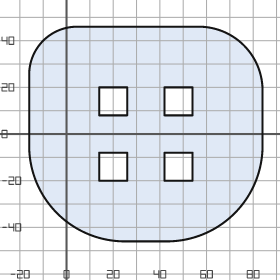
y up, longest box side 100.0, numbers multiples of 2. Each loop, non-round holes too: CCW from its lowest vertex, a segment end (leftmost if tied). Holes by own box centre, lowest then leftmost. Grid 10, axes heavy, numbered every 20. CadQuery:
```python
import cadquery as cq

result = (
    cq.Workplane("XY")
    .moveTo(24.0, -46.0)
    .lineTo(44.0, -46.0)
    .threePointArc((72.0, -34.0), (84.0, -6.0))
    .lineTo(84.0, 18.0)
    .threePointArc((76.0, 38.0), (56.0, 46.0))
    .lineTo(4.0, 46.0)
    .threePointArc((-10.0, 40.0), (-16.0, 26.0))
    .lineTo(-16.0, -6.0)
    .threePointArc((-4.0, -34.0), (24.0, -46.0))
    .close()
    .moveTo(14.0, -20.0)
    .lineTo(26.0, -20.0)
    .lineTo(26.0, -8.0)
    .lineTo(14.0, -8.0)
    .close()
    .moveTo(42.0, -20.0)
    .lineTo(54.0, -20.0)
    .lineTo(54.0, -8.0)
    .lineTo(42.0, -8.0)
    .close()
    .moveTo(14.0, 8.0)
    .lineTo(26.0, 8.0)
    .lineTo(26.0, 20.0)
    .lineTo(14.0, 20.0)
    .close()
    .moveTo(42.0, 8.0)
    .lineTo(54.0, 8.0)
    .lineTo(54.0, 20.0)
    .lineTo(42.0, 20.0)
    .close()
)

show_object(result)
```